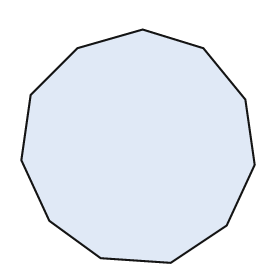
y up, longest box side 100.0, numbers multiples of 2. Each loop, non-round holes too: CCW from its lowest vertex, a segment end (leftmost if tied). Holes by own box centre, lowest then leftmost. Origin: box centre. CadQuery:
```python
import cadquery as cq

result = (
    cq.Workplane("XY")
    .moveTo(14.0, -50.0)
    .lineTo(38.0, -34.0)
    .lineTo(50.0, -8.0)
    .lineTo(46.0, 20.0)
    .lineTo(28.0, 42.0)
    .lineTo(2.0, 50.0)
    .lineTo(-26.0, 42.0)
    .lineTo(-46.0, 22.0)
    .lineTo(-50.0, -6.0)
    .lineTo(-38.0, -32.0)
    .lineTo(-16.0, -48.0)
    .close()
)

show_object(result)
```